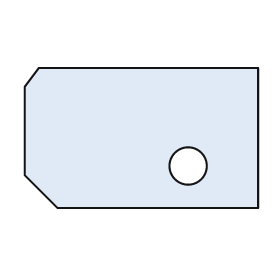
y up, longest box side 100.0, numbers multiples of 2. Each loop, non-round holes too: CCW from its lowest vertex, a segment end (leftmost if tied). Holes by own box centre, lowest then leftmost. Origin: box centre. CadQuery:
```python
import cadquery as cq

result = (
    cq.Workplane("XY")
    .moveTo(-36.0, -30.0)
    .lineTo(50.0, -30.0)
    .lineTo(50.0, 30.0)
    .lineTo(-44.0, 30.0)
    .lineTo(-50.0, 22.0)
    .lineTo(-50.0, -16.0)
    .close()
    .moveTo(20.0, -12.0)
    .circle(8.0)
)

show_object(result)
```